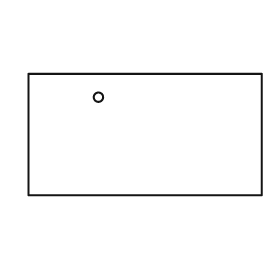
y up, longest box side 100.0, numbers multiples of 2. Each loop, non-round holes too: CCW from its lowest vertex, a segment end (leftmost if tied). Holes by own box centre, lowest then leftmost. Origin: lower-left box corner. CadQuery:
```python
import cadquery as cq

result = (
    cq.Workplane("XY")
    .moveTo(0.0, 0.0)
    .lineTo(100.0, 0.0)
    .lineTo(100.0, 52.0)
    .lineTo(0.0, 52.0)
    .close()
    .moveTo(30.0, 42.0)
    .circle(2.0)
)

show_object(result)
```